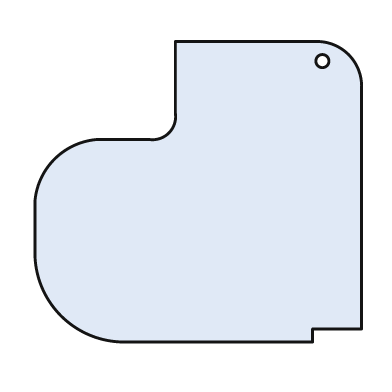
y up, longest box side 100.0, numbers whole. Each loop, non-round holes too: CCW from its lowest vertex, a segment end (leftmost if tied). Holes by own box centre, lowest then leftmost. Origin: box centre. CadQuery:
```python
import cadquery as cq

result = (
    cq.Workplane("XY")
    .moveTo(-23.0, -46.0)
    .lineTo(35.0, -46.0)
    .lineTo(35.0, -42.0)
    .lineTo(50.0, -42.0)
    .lineTo(50.0, 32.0)
    .threePointArc((46.0, 42.0), (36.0, 46.0))
    .lineTo(-7.0, 46.0)
    .lineTo(-7.0, 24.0)
    .threePointArc((-9.0, 18.0), (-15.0, 16.0))
    .lineTo(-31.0, 16.0)
    .threePointArc((-44.0, 10.0), (-50.0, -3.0))
    .lineTo(-50.0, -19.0)
    .threePointArc((-42.0, -38.0), (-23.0, -46.0))
    .close()
    .moveTo(38.0, 40.0)
    .circle(2.0)
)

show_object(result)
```